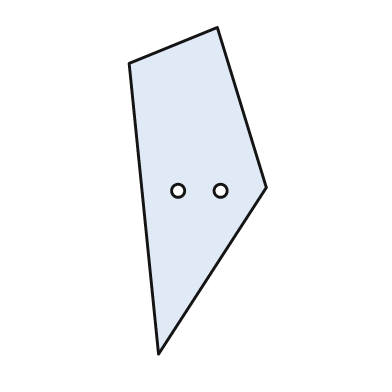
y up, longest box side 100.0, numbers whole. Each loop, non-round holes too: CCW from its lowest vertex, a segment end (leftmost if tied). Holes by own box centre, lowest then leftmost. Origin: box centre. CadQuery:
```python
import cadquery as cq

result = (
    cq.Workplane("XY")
    .moveTo(-12.0, -50.0)
    .lineTo(21.0, 1.0)
    .lineTo(6.0, 50.0)
    .lineTo(-21.0, 39.0)
    .close()
    .moveTo(-6.0, 0.0)
    .circle(2.0)
    .moveTo(7.0, 0.0)
    .circle(2.0)
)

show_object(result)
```